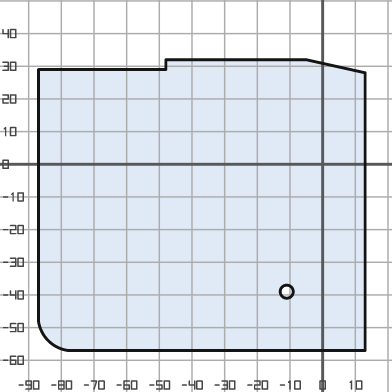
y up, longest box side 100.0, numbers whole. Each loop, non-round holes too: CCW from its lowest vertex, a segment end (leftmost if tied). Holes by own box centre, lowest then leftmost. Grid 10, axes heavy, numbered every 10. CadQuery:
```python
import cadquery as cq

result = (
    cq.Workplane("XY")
    .moveTo(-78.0, -57.0)
    .lineTo(13.0, -57.0)
    .lineTo(13.0, 28.0)
    .lineTo(-5.0, 32.0)
    .lineTo(-48.0, 32.0)
    .lineTo(-48.0, 29.0)
    .lineTo(-87.0, 29.0)
    .lineTo(-87.0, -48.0)
    .threePointArc((-84.0, -54.0), (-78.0, -57.0))
    .close()
    .moveTo(-11.0, -39.0)
    .circle(2.0)
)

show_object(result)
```